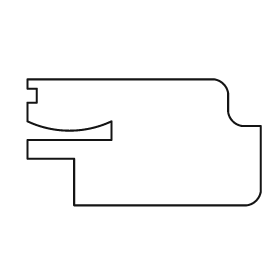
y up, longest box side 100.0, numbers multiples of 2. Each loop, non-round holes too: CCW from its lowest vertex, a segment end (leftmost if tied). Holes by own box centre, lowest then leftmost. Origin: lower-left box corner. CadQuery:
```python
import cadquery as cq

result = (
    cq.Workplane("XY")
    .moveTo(20.0, 0.0)
    .lineTo(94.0, 0.0)
    .threePointArc((98.0, 2.0), (100.0, 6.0))
    .lineTo(100.0, 34.0)
    .lineTo(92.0, 34.0)
    .threePointArc((88.0, 36.0), (86.0, 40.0))
    .lineTo(86.0, 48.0)
    .threePointArc((84.0, 52.0), (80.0, 54.0))
    .lineTo(0.0, 54.0)
    .lineTo(0.0, 50.0)
    .lineTo(4.0, 50.0)
    .lineTo(4.0, 44.0)
    .lineTo(0.0, 44.0)
    .lineTo(0.0, 36.0)
    .threePointArc((18.0, 32.0), (36.0, 36.0))
    .lineTo(36.0, 28.0)
    .lineTo(0.0, 28.0)
    .lineTo(0.0, 20.0)
    .lineTo(20.0, 20.0)
    .close()
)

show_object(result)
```